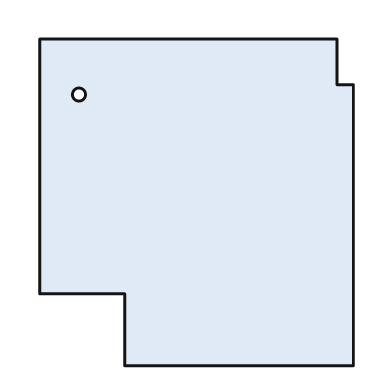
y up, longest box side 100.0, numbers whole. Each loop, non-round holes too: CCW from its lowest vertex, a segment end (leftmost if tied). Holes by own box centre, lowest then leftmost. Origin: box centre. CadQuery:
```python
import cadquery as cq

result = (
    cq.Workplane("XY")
    .moveTo(-22.0, -50.0)
    .lineTo(48.0, -50.0)
    .lineTo(48.0, 36.0)
    .lineTo(43.0, 36.0)
    .lineTo(43.0, 50.0)
    .lineTo(-48.0, 50.0)
    .lineTo(-48.0, -28.0)
    .lineTo(-22.0, -28.0)
    .close()
    .moveTo(-36.0, 33.0)
    .circle(2.0)
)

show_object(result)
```